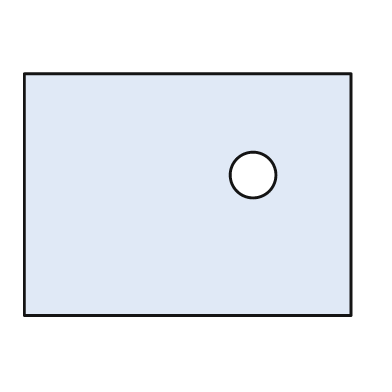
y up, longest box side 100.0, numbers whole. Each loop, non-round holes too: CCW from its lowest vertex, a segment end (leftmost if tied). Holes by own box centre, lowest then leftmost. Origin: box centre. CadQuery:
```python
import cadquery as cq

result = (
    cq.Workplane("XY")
    .moveTo(-50.0, -37.0)
    .lineTo(50.0, -37.0)
    .lineTo(50.0, 37.0)
    .lineTo(-50.0, 37.0)
    .close()
    .moveTo(20.0, 6.0)
    .circle(7.0)
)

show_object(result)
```